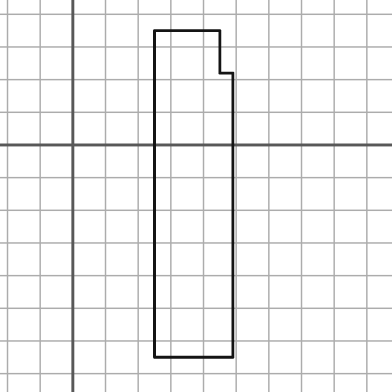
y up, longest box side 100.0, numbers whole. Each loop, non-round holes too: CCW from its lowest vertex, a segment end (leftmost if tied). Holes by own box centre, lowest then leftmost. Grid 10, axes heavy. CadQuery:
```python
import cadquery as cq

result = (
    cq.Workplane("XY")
    .moveTo(25.0, -65.0)
    .lineTo(49.0, -65.0)
    .lineTo(49.0, 22.0)
    .lineTo(45.0, 22.0)
    .lineTo(45.0, 35.0)
    .lineTo(25.0, 35.0)
    .close()
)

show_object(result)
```